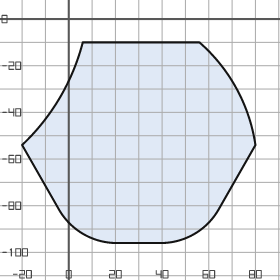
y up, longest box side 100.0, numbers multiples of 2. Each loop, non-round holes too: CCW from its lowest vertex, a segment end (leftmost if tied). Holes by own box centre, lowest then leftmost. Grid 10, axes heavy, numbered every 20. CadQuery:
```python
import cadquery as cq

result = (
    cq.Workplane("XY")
    .moveTo(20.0, -96.0)
    .lineTo(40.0, -96.0)
    .threePointArc((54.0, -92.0), (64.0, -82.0))
    .lineTo(80.0, -54.0)
    .threePointArc((72.0, -30.0), (56.0, -10.0))
    .lineTo(6.0, -10.0)
    .threePointArc((-4.0, -34.0), (-20.0, -54.0))
    .lineTo(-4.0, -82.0)
    .threePointArc((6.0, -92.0), (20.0, -96.0))
    .close()
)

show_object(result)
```